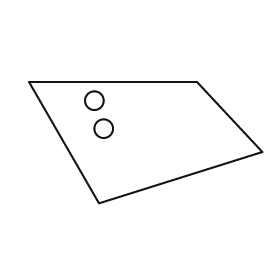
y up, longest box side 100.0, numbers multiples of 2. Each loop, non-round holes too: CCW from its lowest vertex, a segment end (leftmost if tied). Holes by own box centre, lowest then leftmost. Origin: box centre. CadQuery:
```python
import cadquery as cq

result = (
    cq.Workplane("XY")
    .moveTo(-20.0, -26.0)
    .lineTo(50.0, -4.0)
    .lineTo(22.0, 26.0)
    .lineTo(-50.0, 26.0)
    .close()
    .moveTo(-18.0, 6.0)
    .circle(4.0)
    .moveTo(-22.0, 18.0)
    .circle(4.0)
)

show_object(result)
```